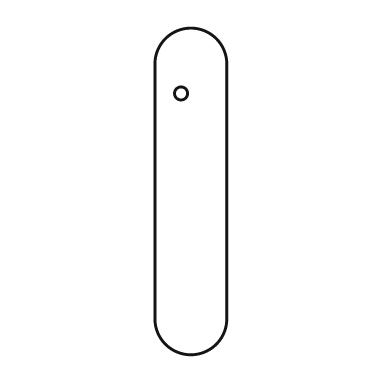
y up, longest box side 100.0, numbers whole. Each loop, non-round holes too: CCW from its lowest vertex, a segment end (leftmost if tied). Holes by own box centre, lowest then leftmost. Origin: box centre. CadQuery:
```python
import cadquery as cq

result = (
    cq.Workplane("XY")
    .moveTo(-11.0, -39.0)
    .threePointArc((0.0, -50.0), (11.0, -39.0))
    .lineTo(11.0, 39.0)
    .threePointArc((0.0, 50.0), (-11.0, 39.0))
    .close()
    .moveTo(-3.0, 30.0)
    .circle(2.0)
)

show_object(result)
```